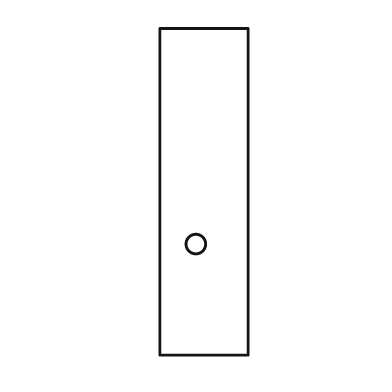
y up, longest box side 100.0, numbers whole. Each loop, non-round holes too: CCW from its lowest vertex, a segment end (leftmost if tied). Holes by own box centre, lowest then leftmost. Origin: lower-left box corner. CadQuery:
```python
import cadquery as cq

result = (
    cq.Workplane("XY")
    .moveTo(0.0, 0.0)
    .lineTo(27.0, 0.0)
    .lineTo(27.0, 100.0)
    .lineTo(0.0, 100.0)
    .close()
    .moveTo(11.0, 34.0)
    .circle(3.0)
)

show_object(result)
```